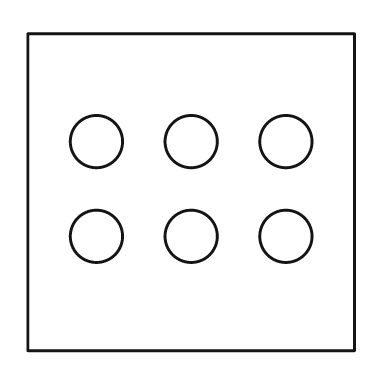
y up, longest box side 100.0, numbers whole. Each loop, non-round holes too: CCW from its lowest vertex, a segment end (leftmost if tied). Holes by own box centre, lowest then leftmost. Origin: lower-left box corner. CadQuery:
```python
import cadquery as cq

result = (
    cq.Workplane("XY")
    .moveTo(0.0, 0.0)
    .lineTo(100.0, 0.0)
    .lineTo(100.0, 97.0)
    .lineTo(0.0, 97.0)
    .close()
    .moveTo(21.0, 35.0)
    .circle(8.0)
    .moveTo(50.0, 35.0)
    .circle(8.0)
    .moveTo(79.0, 35.0)
    .circle(8.0)
    .moveTo(21.0, 64.0)
    .circle(8.0)
    .moveTo(50.0, 64.0)
    .circle(8.0)
    .moveTo(79.0, 64.0)
    .circle(8.0)
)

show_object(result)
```